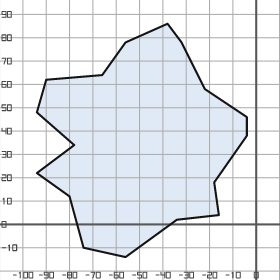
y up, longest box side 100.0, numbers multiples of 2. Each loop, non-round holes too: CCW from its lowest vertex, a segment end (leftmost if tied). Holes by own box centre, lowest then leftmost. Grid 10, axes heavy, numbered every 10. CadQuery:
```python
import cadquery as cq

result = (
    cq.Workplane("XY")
    .moveTo(-56.0, -14.0)
    .lineTo(-34.0, 2.0)
    .lineTo(-16.0, 4.0)
    .lineTo(-18.0, 18.0)
    .lineTo(-4.0, 38.0)
    .lineTo(-4.0, 46.0)
    .lineTo(-22.0, 58.0)
    .lineTo(-32.0, 78.0)
    .lineTo(-38.0, 86.0)
    .lineTo(-56.0, 78.0)
    .lineTo(-66.0, 64.0)
    .lineTo(-90.0, 62.0)
    .lineTo(-94.0, 48.0)
    .lineTo(-78.0, 34.0)
    .lineTo(-94.0, 22.0)
    .lineTo(-80.0, 12.0)
    .lineTo(-74.0, -10.0)
    .close()
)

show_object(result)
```